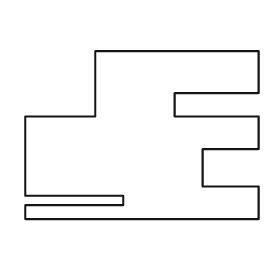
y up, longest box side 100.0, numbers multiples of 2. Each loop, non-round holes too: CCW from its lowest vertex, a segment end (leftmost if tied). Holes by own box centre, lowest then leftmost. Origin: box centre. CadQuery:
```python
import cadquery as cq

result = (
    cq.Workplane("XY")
    .moveTo(-50.0, -36.0)
    .lineTo(50.0, -36.0)
    .lineTo(50.0, -22.0)
    .lineTo(26.0, -22.0)
    .lineTo(26.0, -6.0)
    .lineTo(50.0, -6.0)
    .lineTo(50.0, 8.0)
    .lineTo(14.0, 8.0)
    .lineTo(14.0, 18.0)
    .lineTo(50.0, 18.0)
    .lineTo(50.0, 36.0)
    .lineTo(-20.0, 36.0)
    .lineTo(-20.0, 8.0)
    .lineTo(-50.0, 8.0)
    .lineTo(-50.0, -26.0)
    .lineTo(-8.0, -26.0)
    .lineTo(-8.0, -30.0)
    .lineTo(-50.0, -30.0)
    .close()
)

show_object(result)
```